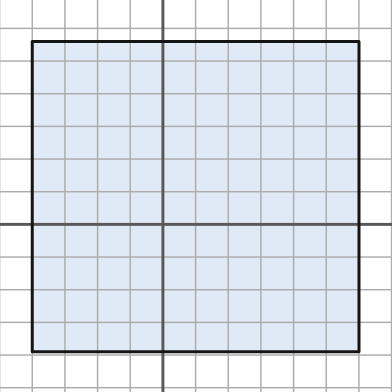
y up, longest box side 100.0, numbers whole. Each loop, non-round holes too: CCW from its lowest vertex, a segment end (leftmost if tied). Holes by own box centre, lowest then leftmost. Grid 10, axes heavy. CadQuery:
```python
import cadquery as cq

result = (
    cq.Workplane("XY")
    .moveTo(-40.0, -39.0)
    .lineTo(60.0, -39.0)
    .lineTo(60.0, 56.0)
    .lineTo(-40.0, 56.0)
    .close()
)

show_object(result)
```